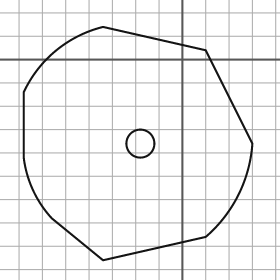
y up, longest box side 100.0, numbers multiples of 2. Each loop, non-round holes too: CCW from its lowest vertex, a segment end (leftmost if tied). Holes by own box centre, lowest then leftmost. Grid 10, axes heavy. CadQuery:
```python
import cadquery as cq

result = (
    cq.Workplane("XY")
    .moveTo(-34.0, -86.0)
    .lineTo(10.0, -76.0)
    .threePointArc((24.0, -58.0), (30.0, -36.0))
    .lineTo(10.0, 4.0)
    .lineTo(-34.0, 14.0)
    .threePointArc((-54.0, 4.0), (-68.0, -14.0))
    .lineTo(-68.0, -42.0)
    .threePointArc((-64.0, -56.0), (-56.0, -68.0))
    .close()
    .moveTo(-18.0, -36.0)
    .circle(6.0)
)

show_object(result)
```